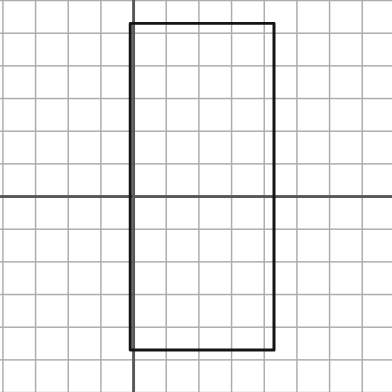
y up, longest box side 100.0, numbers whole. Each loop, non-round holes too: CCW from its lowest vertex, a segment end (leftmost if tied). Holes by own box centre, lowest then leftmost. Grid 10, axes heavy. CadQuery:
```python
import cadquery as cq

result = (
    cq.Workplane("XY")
    .moveTo(-1.0, -47.0)
    .lineTo(43.0, -47.0)
    .lineTo(43.0, 53.0)
    .lineTo(-1.0, 53.0)
    .close()
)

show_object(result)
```